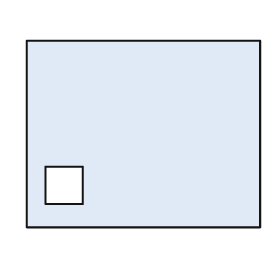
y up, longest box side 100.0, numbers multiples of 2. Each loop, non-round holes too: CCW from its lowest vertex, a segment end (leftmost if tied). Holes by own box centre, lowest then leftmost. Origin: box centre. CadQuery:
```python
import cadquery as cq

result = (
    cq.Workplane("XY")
    .moveTo(-50.0, -40.0)
    .lineTo(50.0, -40.0)
    .lineTo(50.0, 40.0)
    .lineTo(-50.0, 40.0)
    .close()
    .moveTo(-42.0, -30.0)
    .lineTo(-26.0, -30.0)
    .lineTo(-26.0, -14.0)
    .lineTo(-42.0, -14.0)
    .close()
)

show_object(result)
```